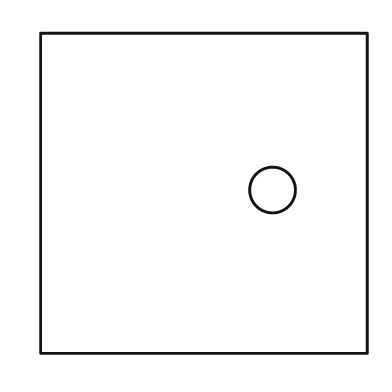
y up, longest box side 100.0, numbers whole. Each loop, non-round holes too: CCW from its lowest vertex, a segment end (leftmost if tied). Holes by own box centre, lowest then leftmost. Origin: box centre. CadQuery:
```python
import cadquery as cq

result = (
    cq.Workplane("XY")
    .moveTo(-50.0, -49.0)
    .lineTo(50.0, -49.0)
    .lineTo(50.0, 49.0)
    .lineTo(-50.0, 49.0)
    .close()
    .moveTo(21.0, 1.0)
    .circle(7.0)
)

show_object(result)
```